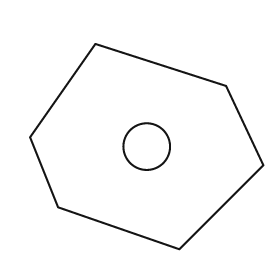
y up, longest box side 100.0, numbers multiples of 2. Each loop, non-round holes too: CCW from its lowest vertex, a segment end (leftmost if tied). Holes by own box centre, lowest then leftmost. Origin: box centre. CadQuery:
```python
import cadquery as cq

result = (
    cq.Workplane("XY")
    .moveTo(14.0, -44.0)
    .lineTo(50.0, -8.0)
    .lineTo(34.0, 26.0)
    .lineTo(-22.0, 44.0)
    .lineTo(-50.0, 4.0)
    .lineTo(-38.0, -26.0)
    .close()
    .moveTo(0.0, 0.0)
    .circle(10.0)
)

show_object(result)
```